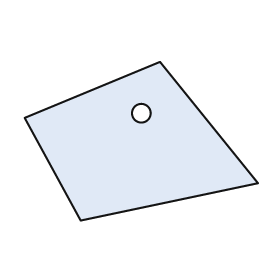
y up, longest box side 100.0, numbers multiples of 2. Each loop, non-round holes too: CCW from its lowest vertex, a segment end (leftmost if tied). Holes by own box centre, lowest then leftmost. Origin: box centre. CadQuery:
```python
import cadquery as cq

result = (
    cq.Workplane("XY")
    .moveTo(-26.0, -34.0)
    .lineTo(50.0, -18.0)
    .lineTo(8.0, 34.0)
    .lineTo(-50.0, 10.0)
    .close()
    .moveTo(0.0, 12.0)
    .circle(4.0)
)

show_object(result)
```